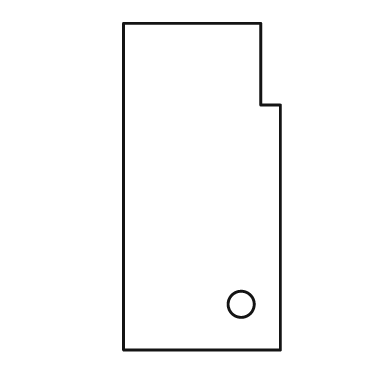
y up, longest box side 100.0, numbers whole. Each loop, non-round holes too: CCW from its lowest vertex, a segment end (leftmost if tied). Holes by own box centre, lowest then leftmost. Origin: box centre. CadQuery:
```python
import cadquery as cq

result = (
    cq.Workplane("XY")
    .moveTo(-24.0, -50.0)
    .lineTo(24.0, -50.0)
    .lineTo(24.0, 25.0)
    .lineTo(18.0, 25.0)
    .lineTo(18.0, 50.0)
    .lineTo(-24.0, 50.0)
    .close()
    .moveTo(12.0, -36.0)
    .circle(4.0)
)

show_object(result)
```